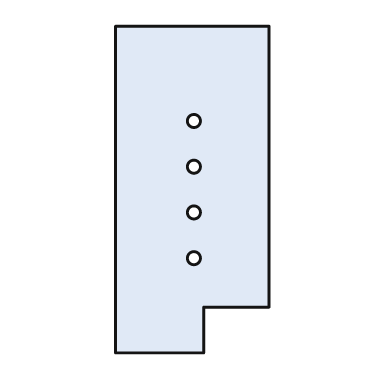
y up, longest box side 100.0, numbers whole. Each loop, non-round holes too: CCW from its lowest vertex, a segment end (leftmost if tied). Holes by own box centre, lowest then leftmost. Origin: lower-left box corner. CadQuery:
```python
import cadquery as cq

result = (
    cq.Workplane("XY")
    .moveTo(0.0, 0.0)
    .lineTo(27.0, 0.0)
    .lineTo(27.0, 14.0)
    .lineTo(47.0, 14.0)
    .lineTo(47.0, 100.0)
    .lineTo(0.0, 100.0)
    .close()
    .moveTo(24.0, 29.0)
    .circle(2.0)
    .moveTo(24.0, 43.0)
    .circle(2.0)
    .moveTo(24.0, 57.0)
    .circle(2.0)
    .moveTo(24.0, 71.0)
    .circle(2.0)
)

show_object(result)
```